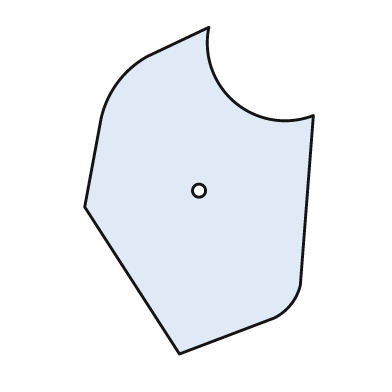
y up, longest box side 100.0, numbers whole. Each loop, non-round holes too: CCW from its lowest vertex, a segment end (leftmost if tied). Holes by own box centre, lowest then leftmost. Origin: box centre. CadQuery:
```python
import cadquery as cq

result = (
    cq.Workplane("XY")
    .moveTo(-6.0, -50.0)
    .lineTo(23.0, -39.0)
    .threePointArc((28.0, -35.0), (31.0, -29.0))
    .lineTo(35.0, 23.0)
    .threePointArc((11.0, 27.0), (3.0, 50.0))
    .lineTo(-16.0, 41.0)
    .threePointArc((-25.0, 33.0), (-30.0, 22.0))
    .lineTo(-35.0, -5.0)
    .close()
    .moveTo(0.0, 0.0)
    .circle(2.0)
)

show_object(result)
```